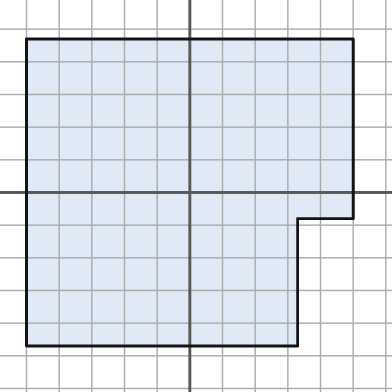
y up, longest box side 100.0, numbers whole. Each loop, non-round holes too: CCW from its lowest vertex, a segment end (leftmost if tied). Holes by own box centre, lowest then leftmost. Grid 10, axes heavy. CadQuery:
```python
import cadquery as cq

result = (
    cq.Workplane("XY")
    .moveTo(-50.0, -47.0)
    .lineTo(33.0, -47.0)
    .lineTo(33.0, -8.0)
    .lineTo(50.0, -8.0)
    .lineTo(50.0, 47.0)
    .lineTo(-50.0, 47.0)
    .close()
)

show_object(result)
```